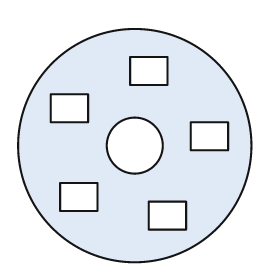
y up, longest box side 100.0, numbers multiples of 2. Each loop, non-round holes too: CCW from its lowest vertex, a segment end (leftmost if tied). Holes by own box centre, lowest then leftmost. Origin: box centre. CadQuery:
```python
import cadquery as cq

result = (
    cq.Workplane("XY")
    .moveTo(0.0, 0.0)
    .circle(50.0)
    .moveTo(6.0, -36.0)
    .lineTo(22.0, -36.0)
    .lineTo(22.0, -24.0)
    .lineTo(6.0, -24.0)
    .close()
    .moveTo(-32.0, -28.0)
    .lineTo(-16.0, -28.0)
    .lineTo(-16.0, -16.0)
    .lineTo(-32.0, -16.0)
    .close()
    .moveTo(0.0, 0.0)
    .circle(12.0)
    .moveTo(24.0, -2.0)
    .lineTo(40.0, -2.0)
    .lineTo(40.0, 10.0)
    .lineTo(24.0, 10.0)
    .close()
    .moveTo(-36.0, 10.0)
    .lineTo(-20.0, 10.0)
    .lineTo(-20.0, 22.0)
    .lineTo(-36.0, 22.0)
    .close()
    .moveTo(-2.0, 26.0)
    .lineTo(14.0, 26.0)
    .lineTo(14.0, 38.0)
    .lineTo(-2.0, 38.0)
    .close()
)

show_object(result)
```